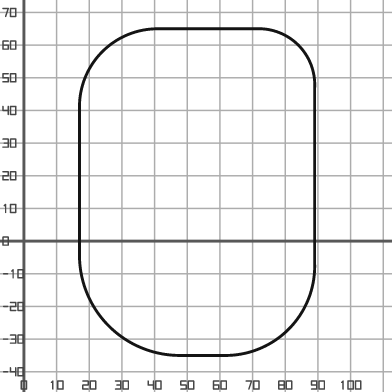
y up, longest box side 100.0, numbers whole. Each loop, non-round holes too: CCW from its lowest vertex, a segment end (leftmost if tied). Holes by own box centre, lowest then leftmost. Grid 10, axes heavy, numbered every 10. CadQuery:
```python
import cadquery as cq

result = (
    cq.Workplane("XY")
    .moveTo(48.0, -35.0)
    .lineTo(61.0, -35.0)
    .threePointArc((81.0, -27.0), (89.0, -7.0))
    .lineTo(89.0, 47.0)
    .threePointArc((84.0, 60.0), (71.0, 65.0))
    .lineTo(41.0, 65.0)
    .threePointArc((24.0, 58.0), (17.0, 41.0))
    .lineTo(17.0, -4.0)
    .threePointArc((26.0, -26.0), (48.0, -35.0))
    .close()
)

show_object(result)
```